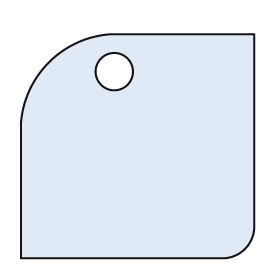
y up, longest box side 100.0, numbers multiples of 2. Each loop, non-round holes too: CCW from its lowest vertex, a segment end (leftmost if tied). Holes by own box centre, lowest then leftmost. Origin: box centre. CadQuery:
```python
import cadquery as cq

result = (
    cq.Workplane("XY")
    .moveTo(-50.0, -48.0)
    .lineTo(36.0, -48.0)
    .threePointArc((46.0, -44.0), (50.0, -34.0))
    .lineTo(50.0, 48.0)
    .lineTo(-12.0, 48.0)
    .threePointArc((-38.0, 36.0), (-50.0, 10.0))
    .close()
    .moveTo(-10.0, 32.0)
    .circle(8.0)
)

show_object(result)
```